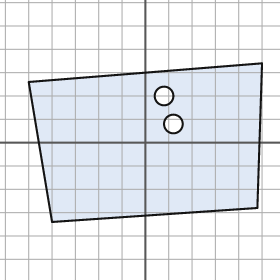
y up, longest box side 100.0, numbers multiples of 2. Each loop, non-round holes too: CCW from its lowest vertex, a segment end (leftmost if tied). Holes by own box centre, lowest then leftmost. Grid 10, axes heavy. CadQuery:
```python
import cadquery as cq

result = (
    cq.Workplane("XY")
    .moveTo(-40.0, -34.0)
    .lineTo(48.0, -28.0)
    .lineTo(50.0, 34.0)
    .lineTo(-50.0, 26.0)
    .close()
    .moveTo(12.0, 8.0)
    .circle(4.0)
    .moveTo(8.0, 20.0)
    .circle(4.0)
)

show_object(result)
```